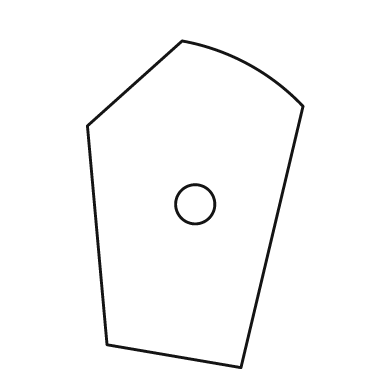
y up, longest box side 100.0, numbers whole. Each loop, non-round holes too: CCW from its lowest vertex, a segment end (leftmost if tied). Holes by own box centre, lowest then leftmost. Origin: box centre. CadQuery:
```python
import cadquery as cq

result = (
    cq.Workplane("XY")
    .moveTo(14.0, -50.0)
    .lineTo(33.0, 30.0)
    .threePointArc((16.0, 43.0), (-4.0, 50.0))
    .lineTo(-33.0, 24.0)
    .lineTo(-27.0, -43.0)
    .close()
    .moveTo(0.0, 0.0)
    .circle(6.0)
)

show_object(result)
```